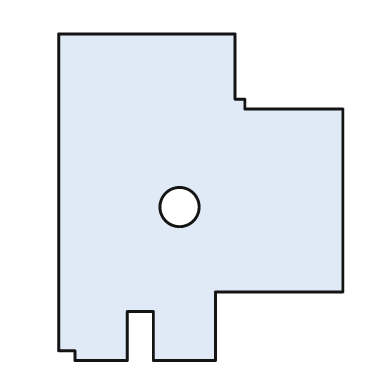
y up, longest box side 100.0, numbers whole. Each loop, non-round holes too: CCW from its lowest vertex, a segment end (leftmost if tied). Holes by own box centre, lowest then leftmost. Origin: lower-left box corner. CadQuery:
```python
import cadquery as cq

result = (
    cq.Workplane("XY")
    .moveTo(5.0, 0.0)
    .lineTo(21.0, 0.0)
    .lineTo(21.0, 15.0)
    .lineTo(29.0, 15.0)
    .lineTo(29.0, 0.0)
    .lineTo(48.0, 0.0)
    .lineTo(48.0, 21.0)
    .lineTo(87.0, 21.0)
    .lineTo(87.0, 77.0)
    .lineTo(57.0, 77.0)
    .lineTo(57.0, 80.0)
    .lineTo(54.0, 80.0)
    .lineTo(54.0, 100.0)
    .lineTo(0.0, 100.0)
    .lineTo(0.0, 3.0)
    .lineTo(5.0, 3.0)
    .close()
    .moveTo(37.0, 47.0)
    .circle(6.0)
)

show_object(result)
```